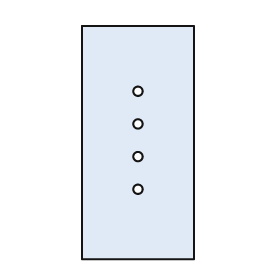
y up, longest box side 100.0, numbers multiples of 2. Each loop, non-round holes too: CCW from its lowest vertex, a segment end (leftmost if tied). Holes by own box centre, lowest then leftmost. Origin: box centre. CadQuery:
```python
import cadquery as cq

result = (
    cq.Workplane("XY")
    .moveTo(-24.0, -50.0)
    .lineTo(24.0, -50.0)
    .lineTo(24.0, 50.0)
    .lineTo(-24.0, 50.0)
    .close()
    .moveTo(0.0, -20.0)
    .circle(2.0)
    .moveTo(0.0, -6.0)
    .circle(2.0)
    .moveTo(0.0, 8.0)
    .circle(2.0)
    .moveTo(0.0, 22.0)
    .circle(2.0)
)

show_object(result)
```